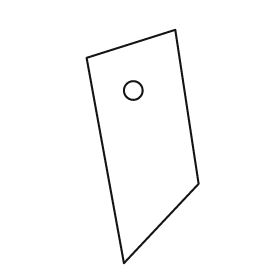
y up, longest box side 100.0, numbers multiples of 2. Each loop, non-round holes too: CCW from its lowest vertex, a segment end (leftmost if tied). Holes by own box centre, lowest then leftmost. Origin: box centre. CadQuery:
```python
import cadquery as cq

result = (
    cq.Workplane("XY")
    .moveTo(-8.0, -50.0)
    .lineTo(24.0, -16.0)
    .lineTo(14.0, 50.0)
    .lineTo(-24.0, 38.0)
    .close()
    .moveTo(-4.0, 24.0)
    .circle(4.0)
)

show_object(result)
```